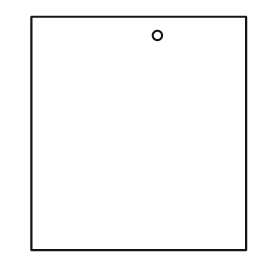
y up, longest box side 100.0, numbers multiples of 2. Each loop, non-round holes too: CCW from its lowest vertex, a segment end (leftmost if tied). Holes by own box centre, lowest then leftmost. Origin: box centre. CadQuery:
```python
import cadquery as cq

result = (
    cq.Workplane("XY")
    .moveTo(-46.0, -50.0)
    .lineTo(46.0, -50.0)
    .lineTo(46.0, 50.0)
    .lineTo(-46.0, 50.0)
    .close()
    .moveTo(8.0, 42.0)
    .circle(2.0)
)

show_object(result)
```